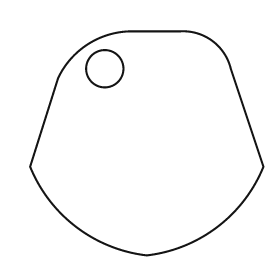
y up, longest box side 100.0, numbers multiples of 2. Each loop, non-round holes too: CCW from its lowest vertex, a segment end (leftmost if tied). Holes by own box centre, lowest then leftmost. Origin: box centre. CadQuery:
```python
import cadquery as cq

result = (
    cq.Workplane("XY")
    .moveTo(0.0, -48.0)
    .threePointArc((30.0, -36.0), (50.0, -10.0))
    .lineTo(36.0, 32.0)
    .threePointArc((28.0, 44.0), (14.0, 48.0))
    .lineTo(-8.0, 48.0)
    .threePointArc((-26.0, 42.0), (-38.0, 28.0))
    .lineTo(-50.0, -10.0)
    .threePointArc((-30.0, -36.0), (0.0, -48.0))
    .close()
    .moveTo(-18.0, 32.0)
    .circle(8.0)
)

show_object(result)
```